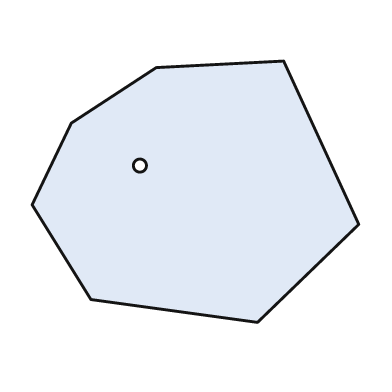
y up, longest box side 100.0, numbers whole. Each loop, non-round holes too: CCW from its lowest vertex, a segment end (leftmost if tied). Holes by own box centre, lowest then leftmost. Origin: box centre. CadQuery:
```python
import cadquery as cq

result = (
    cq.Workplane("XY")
    .moveTo(19.0, -40.0)
    .lineTo(50.0, -10.0)
    .lineTo(27.0, 40.0)
    .lineTo(-12.0, 38.0)
    .lineTo(-38.0, 21.0)
    .lineTo(-50.0, -4.0)
    .lineTo(-32.0, -33.0)
    .close()
    .moveTo(-17.0, 8.0)
    .circle(2.0)
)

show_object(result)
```